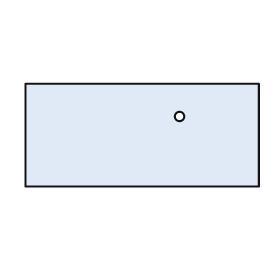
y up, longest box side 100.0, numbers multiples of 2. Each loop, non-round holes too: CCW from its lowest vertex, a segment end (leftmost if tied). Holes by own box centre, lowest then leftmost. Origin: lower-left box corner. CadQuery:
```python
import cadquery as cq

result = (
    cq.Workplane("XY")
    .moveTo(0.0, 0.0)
    .lineTo(100.0, 0.0)
    .lineTo(100.0, 44.0)
    .lineTo(0.0, 44.0)
    .close()
    .moveTo(66.0, 30.0)
    .circle(2.0)
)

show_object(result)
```